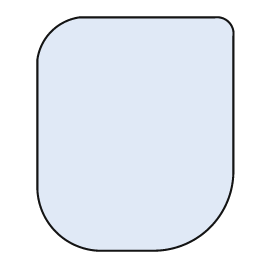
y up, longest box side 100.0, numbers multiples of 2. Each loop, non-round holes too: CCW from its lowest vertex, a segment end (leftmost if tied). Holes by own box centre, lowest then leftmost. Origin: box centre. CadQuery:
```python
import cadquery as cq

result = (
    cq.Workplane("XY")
    .moveTo(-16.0, -50.0)
    .lineTo(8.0, -50.0)
    .threePointArc((32.0, -40.0), (42.0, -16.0))
    .lineTo(42.0, 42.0)
    .threePointArc((40.0, 48.0), (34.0, 50.0))
    .lineTo(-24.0, 50.0)
    .threePointArc((-36.0, 44.0), (-42.0, 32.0))
    .lineTo(-42.0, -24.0)
    .threePointArc((-34.0, -42.0), (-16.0, -50.0))
    .close()
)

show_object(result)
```